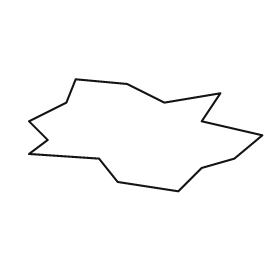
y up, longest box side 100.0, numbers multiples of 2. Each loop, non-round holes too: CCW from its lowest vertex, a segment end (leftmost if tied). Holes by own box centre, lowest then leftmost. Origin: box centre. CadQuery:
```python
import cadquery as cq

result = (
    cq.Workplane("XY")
    .moveTo(14.0, -24.0)
    .lineTo(24.0, -14.0)
    .lineTo(38.0, -10.0)
    .lineTo(50.0, 0.0)
    .lineTo(24.0, 6.0)
    .lineTo(32.0, 18.0)
    .lineTo(8.0, 14.0)
    .lineTo(-8.0, 22.0)
    .lineTo(-30.0, 24.0)
    .lineTo(-34.0, 14.0)
    .lineTo(-50.0, 6.0)
    .lineTo(-42.0, -2.0)
    .lineTo(-50.0, -8.0)
    .lineTo(-20.0, -10.0)
    .lineTo(-12.0, -20.0)
    .close()
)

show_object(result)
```